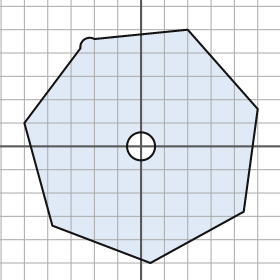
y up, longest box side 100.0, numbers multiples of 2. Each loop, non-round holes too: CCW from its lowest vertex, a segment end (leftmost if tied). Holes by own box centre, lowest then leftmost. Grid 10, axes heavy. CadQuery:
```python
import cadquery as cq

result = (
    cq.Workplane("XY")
    .moveTo(4.0, -50.0)
    .lineTo(44.0, -28.0)
    .lineTo(50.0, 16.0)
    .lineTo(20.0, 50.0)
    .lineTo(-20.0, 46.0)
    .threePointArc((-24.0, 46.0), (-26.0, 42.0))
    .lineTo(-50.0, 10.0)
    .lineTo(-38.0, -34.0)
    .close()
    .moveTo(0.0, 0.0)
    .circle(6.0)
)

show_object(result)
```